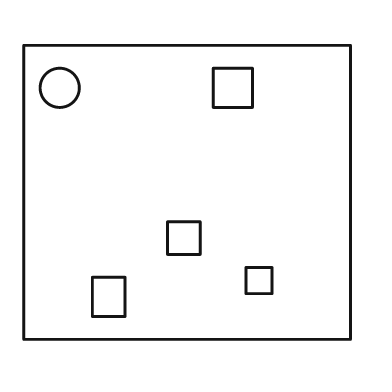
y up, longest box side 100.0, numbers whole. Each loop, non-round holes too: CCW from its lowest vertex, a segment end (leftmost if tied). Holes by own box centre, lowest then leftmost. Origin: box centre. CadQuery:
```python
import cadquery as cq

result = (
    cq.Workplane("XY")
    .moveTo(-50.0, -45.0)
    .lineTo(50.0, -45.0)
    .lineTo(50.0, 45.0)
    .lineTo(-50.0, 45.0)
    .close()
    .moveTo(-29.0, -38.0)
    .lineTo(-19.0, -38.0)
    .lineTo(-19.0, -26.0)
    .lineTo(-29.0, -26.0)
    .close()
    .moveTo(18.0, -31.0)
    .lineTo(26.0, -31.0)
    .lineTo(26.0, -23.0)
    .lineTo(18.0, -23.0)
    .close()
    .moveTo(-6.0, -19.0)
    .lineTo(4.0, -19.0)
    .lineTo(4.0, -9.0)
    .lineTo(-6.0, -9.0)
    .close()
    .moveTo(-39.0, 32.0)
    .circle(6.0)
    .moveTo(8.0, 26.0)
    .lineTo(20.0, 26.0)
    .lineTo(20.0, 38.0)
    .lineTo(8.0, 38.0)
    .close()
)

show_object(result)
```